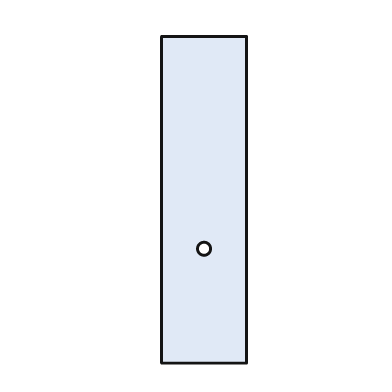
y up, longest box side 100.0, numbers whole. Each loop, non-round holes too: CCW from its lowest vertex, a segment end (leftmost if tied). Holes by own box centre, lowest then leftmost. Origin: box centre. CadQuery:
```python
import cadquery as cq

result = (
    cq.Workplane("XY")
    .moveTo(-13.0, -50.0)
    .lineTo(13.0, -50.0)
    .lineTo(13.0, 50.0)
    .lineTo(-13.0, 50.0)
    .close()
    .moveTo(0.0, -15.0)
    .circle(2.0)
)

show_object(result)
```